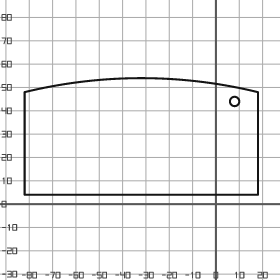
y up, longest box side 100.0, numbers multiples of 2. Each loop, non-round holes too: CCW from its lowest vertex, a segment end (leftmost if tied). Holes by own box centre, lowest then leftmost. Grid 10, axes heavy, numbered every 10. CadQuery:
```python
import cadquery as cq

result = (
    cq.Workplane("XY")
    .moveTo(-82.0, 4.0)
    .lineTo(18.0, 4.0)
    .lineTo(18.0, 48.0)
    .threePointArc((-32.0, 54.0), (-82.0, 48.0))
    .close()
    .moveTo(8.0, 44.0)
    .circle(2.0)
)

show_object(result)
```